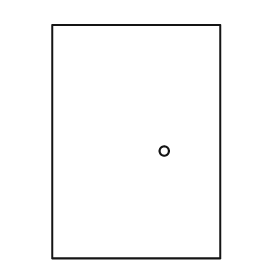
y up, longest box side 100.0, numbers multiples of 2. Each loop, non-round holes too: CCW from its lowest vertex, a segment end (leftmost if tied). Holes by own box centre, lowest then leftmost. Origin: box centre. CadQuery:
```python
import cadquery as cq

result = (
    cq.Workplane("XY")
    .moveTo(-36.0, -50.0)
    .lineTo(36.0, -50.0)
    .lineTo(36.0, 50.0)
    .lineTo(-36.0, 50.0)
    .close()
    .moveTo(12.0, -4.0)
    .circle(2.0)
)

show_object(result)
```